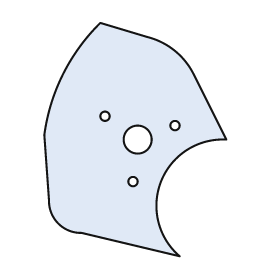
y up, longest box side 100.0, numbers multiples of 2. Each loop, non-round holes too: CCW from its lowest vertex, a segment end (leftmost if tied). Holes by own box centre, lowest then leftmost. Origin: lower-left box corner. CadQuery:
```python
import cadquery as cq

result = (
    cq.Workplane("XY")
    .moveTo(58.0, 0.0)
    .threePointArc((50.0, 32.0), (78.0, 50.0))
    .lineTo(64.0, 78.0)
    .threePointArc((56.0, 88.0), (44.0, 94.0))
    .lineTo(24.0, 100.0)
    .threePointArc((8.0, 78.0), (0.0, 52.0))
    .lineTo(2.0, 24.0)
    .threePointArc((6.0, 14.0), (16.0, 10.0))
    .close()
    .moveTo(38.0, 32.0)
    .circle(2.0)
    .moveTo(40.0, 50.0)
    .circle(6.0)
    .moveTo(56.0, 56.0)
    .circle(2.0)
    .moveTo(26.0, 60.0)
    .circle(2.0)
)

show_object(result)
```